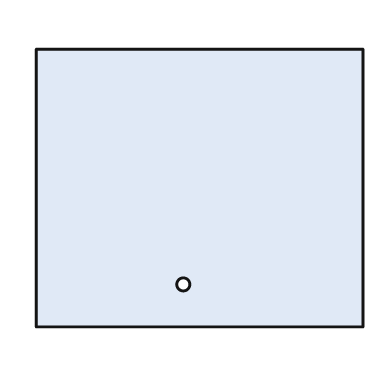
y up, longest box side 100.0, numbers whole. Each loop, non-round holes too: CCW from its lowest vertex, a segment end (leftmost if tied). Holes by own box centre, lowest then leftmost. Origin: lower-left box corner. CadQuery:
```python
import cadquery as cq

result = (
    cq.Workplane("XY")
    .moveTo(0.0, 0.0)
    .lineTo(100.0, 0.0)
    .lineTo(100.0, 85.0)
    .lineTo(0.0, 85.0)
    .close()
    .moveTo(45.0, 13.0)
    .circle(2.0)
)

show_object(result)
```